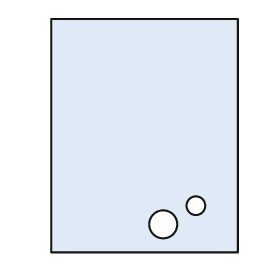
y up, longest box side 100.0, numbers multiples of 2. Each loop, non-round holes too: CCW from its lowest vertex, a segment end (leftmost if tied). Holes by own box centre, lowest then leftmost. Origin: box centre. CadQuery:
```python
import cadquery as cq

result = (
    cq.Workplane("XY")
    .moveTo(-40.0, -50.0)
    .lineTo(40.0, -50.0)
    .lineTo(40.0, 50.0)
    .lineTo(-40.0, 50.0)
    .close()
    .moveTo(8.0, -38.0)
    .circle(6.0)
    .moveTo(22.0, -30.0)
    .circle(4.0)
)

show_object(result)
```